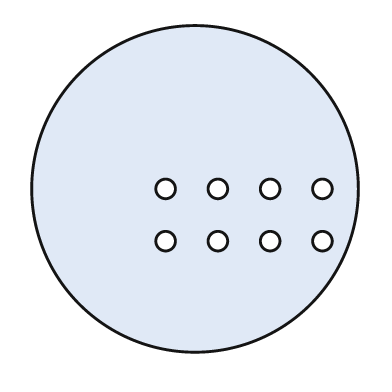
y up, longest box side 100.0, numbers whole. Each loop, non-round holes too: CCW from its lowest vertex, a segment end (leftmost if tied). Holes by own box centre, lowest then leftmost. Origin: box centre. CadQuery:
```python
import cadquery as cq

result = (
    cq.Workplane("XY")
    .moveTo(0.0, 0.0)
    .circle(50.0)
    .moveTo(-9.0, -16.0)
    .circle(3.0)
    .moveTo(7.0, -16.0)
    .circle(3.0)
    .moveTo(23.0, -16.0)
    .circle(3.0)
    .moveTo(39.0, -16.0)
    .circle(3.0)
    .moveTo(-9.0, 0.0)
    .circle(3.0)
    .moveTo(7.0, 0.0)
    .circle(3.0)
    .moveTo(23.0, 0.0)
    .circle(3.0)
    .moveTo(39.0, 0.0)
    .circle(3.0)
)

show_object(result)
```